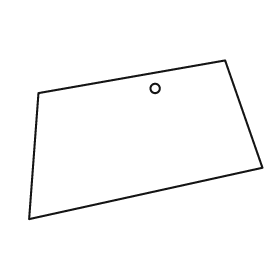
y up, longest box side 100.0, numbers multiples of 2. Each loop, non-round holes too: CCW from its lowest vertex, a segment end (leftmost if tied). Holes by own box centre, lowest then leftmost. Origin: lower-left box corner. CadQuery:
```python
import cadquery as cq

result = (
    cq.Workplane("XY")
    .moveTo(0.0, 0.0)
    .lineTo(100.0, 22.0)
    .lineTo(84.0, 68.0)
    .lineTo(4.0, 54.0)
    .close()
    .moveTo(54.0, 56.0)
    .circle(2.0)
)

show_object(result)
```